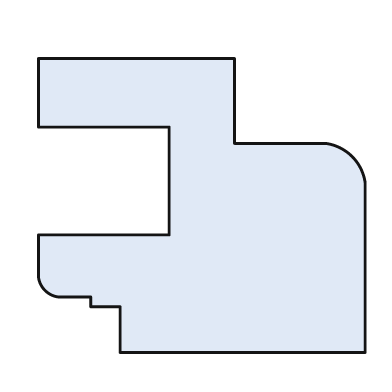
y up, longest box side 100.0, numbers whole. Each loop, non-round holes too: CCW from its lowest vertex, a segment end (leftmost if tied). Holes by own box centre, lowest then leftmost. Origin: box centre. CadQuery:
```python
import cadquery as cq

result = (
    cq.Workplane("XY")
    .moveTo(-25.0, -45.0)
    .lineTo(50.0, -45.0)
    .lineTo(50.0, 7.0)
    .threePointArc((46.0, 15.0), (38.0, 19.0))
    .lineTo(10.0, 19.0)
    .lineTo(10.0, 45.0)
    .lineTo(-50.0, 45.0)
    .lineTo(-50.0, 24.0)
    .lineTo(-10.0, 24.0)
    .lineTo(-10.0, -9.0)
    .lineTo(-50.0, -9.0)
    .lineTo(-50.0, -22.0)
    .threePointArc((-48.0, -26.0), (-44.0, -28.0))
    .lineTo(-34.0, -28.0)
    .lineTo(-34.0, -31.0)
    .lineTo(-25.0, -31.0)
    .close()
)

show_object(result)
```